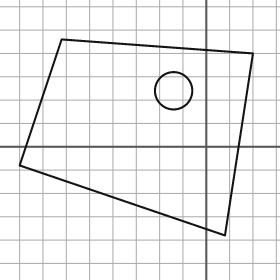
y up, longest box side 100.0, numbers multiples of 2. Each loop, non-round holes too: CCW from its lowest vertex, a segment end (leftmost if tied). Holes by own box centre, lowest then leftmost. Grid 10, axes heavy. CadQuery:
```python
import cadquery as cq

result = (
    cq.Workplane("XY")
    .moveTo(8.0, -38.0)
    .lineTo(20.0, 40.0)
    .lineTo(-62.0, 46.0)
    .lineTo(-80.0, -8.0)
    .close()
    .moveTo(-14.0, 24.0)
    .circle(8.0)
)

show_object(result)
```